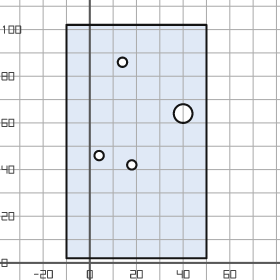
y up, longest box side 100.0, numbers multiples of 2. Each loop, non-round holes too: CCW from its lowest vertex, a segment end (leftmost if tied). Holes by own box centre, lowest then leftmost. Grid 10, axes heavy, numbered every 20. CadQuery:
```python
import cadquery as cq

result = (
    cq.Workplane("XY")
    .moveTo(-10.0, 2.0)
    .lineTo(50.0, 2.0)
    .lineTo(50.0, 102.0)
    .lineTo(-10.0, 102.0)
    .close()
    .moveTo(18.0, 42.0)
    .circle(2.0)
    .moveTo(4.0, 46.0)
    .circle(2.0)
    .moveTo(40.0, 64.0)
    .circle(4.0)
    .moveTo(14.0, 86.0)
    .circle(2.0)
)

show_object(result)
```